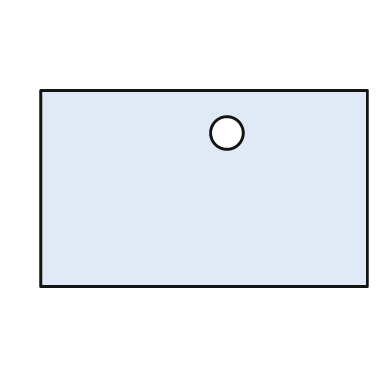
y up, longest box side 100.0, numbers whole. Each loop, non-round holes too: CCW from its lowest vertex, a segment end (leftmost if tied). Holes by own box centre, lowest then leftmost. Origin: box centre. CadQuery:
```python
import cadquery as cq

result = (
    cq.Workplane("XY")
    .moveTo(-50.0, -30.0)
    .lineTo(50.0, -30.0)
    .lineTo(50.0, 30.0)
    .lineTo(-50.0, 30.0)
    .close()
    .moveTo(7.0, 17.0)
    .circle(5.0)
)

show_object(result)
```